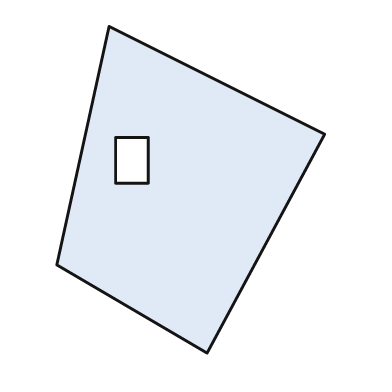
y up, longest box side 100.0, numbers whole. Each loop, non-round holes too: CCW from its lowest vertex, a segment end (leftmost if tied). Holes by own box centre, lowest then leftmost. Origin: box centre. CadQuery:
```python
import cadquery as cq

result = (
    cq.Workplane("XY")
    .moveTo(5.0, -50.0)
    .lineTo(41.0, 17.0)
    .lineTo(-25.0, 50.0)
    .lineTo(-41.0, -23.0)
    .close()
    .moveTo(-23.0, 2.0)
    .lineTo(-13.0, 2.0)
    .lineTo(-13.0, 16.0)
    .lineTo(-23.0, 16.0)
    .close()
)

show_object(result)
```